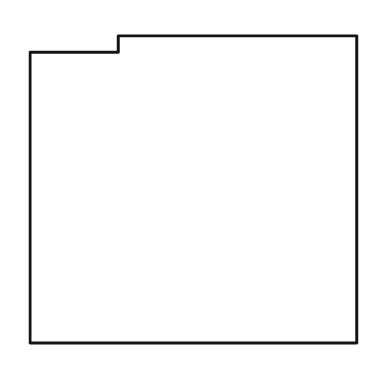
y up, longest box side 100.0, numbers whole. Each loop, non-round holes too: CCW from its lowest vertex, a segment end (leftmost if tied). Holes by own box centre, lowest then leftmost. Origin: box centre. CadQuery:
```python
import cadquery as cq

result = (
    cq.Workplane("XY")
    .moveTo(-50.0, -47.0)
    .lineTo(50.0, -47.0)
    .lineTo(50.0, 47.0)
    .lineTo(-23.0, 47.0)
    .lineTo(-23.0, 42.0)
    .lineTo(-50.0, 42.0)
    .close()
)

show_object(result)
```